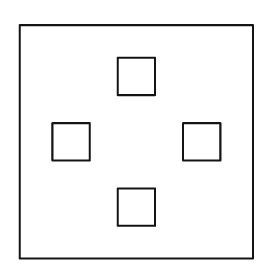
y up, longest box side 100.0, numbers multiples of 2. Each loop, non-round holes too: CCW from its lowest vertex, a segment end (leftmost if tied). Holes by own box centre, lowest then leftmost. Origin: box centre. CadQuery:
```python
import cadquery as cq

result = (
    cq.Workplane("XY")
    .moveTo(-50.0, -50.0)
    .lineTo(50.0, -50.0)
    .lineTo(50.0, 50.0)
    .lineTo(-50.0, 50.0)
    .close()
    .moveTo(-8.0, -36.0)
    .lineTo(8.0, -36.0)
    .lineTo(8.0, -20.0)
    .lineTo(-8.0, -20.0)
    .close()
    .moveTo(-36.0, -8.0)
    .lineTo(-20.0, -8.0)
    .lineTo(-20.0, 8.0)
    .lineTo(-36.0, 8.0)
    .close()
    .moveTo(20.0, -8.0)
    .lineTo(36.0, -8.0)
    .lineTo(36.0, 8.0)
    .lineTo(20.0, 8.0)
    .close()
    .moveTo(-8.0, 20.0)
    .lineTo(8.0, 20.0)
    .lineTo(8.0, 36.0)
    .lineTo(-8.0, 36.0)
    .close()
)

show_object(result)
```